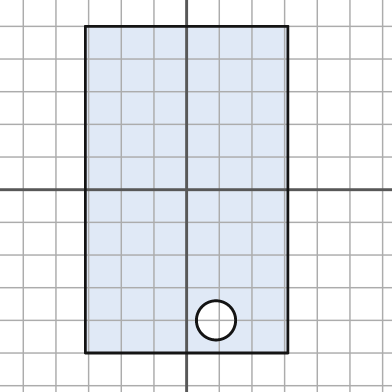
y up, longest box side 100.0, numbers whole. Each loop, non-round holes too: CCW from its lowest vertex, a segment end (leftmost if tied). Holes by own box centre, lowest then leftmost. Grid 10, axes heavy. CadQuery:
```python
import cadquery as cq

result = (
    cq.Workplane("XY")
    .moveTo(-31.0, -50.0)
    .lineTo(31.0, -50.0)
    .lineTo(31.0, 50.0)
    .lineTo(-31.0, 50.0)
    .close()
    .moveTo(9.0, -40.0)
    .circle(6.0)
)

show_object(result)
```